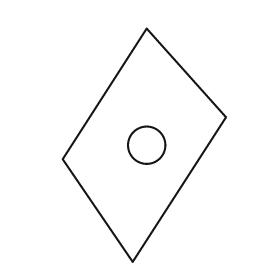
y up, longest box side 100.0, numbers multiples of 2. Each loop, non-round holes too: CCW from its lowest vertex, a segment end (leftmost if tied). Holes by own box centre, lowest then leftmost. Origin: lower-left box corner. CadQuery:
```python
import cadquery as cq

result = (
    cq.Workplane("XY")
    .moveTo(30.0, 0.0)
    .lineTo(70.0, 62.0)
    .lineTo(36.0, 100.0)
    .lineTo(0.0, 44.0)
    .close()
    .moveTo(36.0, 50.0)
    .circle(8.0)
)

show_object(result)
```